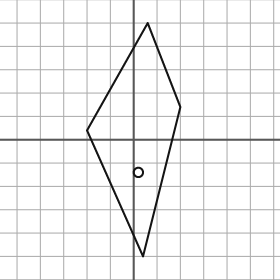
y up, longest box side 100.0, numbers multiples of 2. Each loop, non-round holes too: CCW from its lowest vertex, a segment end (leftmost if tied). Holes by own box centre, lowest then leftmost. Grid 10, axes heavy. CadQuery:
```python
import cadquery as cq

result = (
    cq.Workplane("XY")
    .moveTo(4.0, -50.0)
    .lineTo(20.0, 14.0)
    .lineTo(6.0, 50.0)
    .lineTo(-20.0, 4.0)
    .close()
    .moveTo(2.0, -14.0)
    .circle(2.0)
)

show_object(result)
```